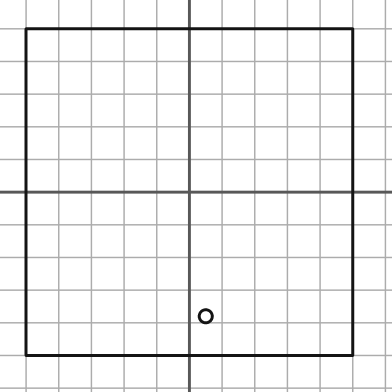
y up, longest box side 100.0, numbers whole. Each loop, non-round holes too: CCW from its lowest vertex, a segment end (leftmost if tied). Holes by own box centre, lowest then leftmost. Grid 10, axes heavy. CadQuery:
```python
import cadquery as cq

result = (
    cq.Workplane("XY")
    .moveTo(-50.0, -50.0)
    .lineTo(50.0, -50.0)
    .lineTo(50.0, 50.0)
    .lineTo(-50.0, 50.0)
    .close()
    .moveTo(5.0, -38.0)
    .circle(2.0)
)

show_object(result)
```